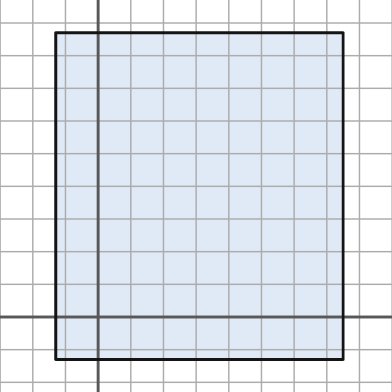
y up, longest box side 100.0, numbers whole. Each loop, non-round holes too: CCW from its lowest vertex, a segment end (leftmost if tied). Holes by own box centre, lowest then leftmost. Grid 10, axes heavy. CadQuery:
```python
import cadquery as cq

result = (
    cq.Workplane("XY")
    .moveTo(-13.0, -13.0)
    .lineTo(75.0, -13.0)
    .lineTo(75.0, 87.0)
    .lineTo(-13.0, 87.0)
    .close()
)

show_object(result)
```